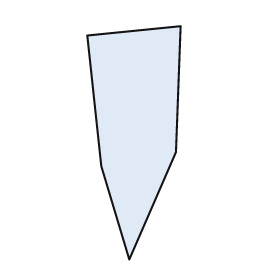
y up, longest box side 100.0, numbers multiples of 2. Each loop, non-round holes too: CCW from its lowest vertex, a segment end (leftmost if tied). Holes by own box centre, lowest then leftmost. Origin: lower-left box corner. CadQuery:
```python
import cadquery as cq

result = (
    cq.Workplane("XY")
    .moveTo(18.0, 0.0)
    .lineTo(38.0, 46.0)
    .lineTo(40.0, 100.0)
    .lineTo(0.0, 96.0)
    .lineTo(6.0, 40.0)
    .close()
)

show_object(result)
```